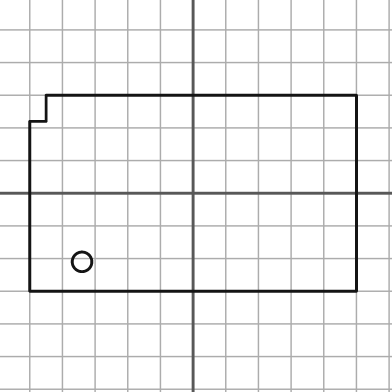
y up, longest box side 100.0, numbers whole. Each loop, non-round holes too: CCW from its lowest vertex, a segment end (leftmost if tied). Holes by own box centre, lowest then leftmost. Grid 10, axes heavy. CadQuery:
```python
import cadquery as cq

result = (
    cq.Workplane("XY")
    .moveTo(-50.0, -30.0)
    .lineTo(50.0, -30.0)
    .lineTo(50.0, 30.0)
    .lineTo(-45.0, 30.0)
    .lineTo(-45.0, 22.0)
    .lineTo(-50.0, 22.0)
    .close()
    .moveTo(-34.0, -21.0)
    .circle(3.0)
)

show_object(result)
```